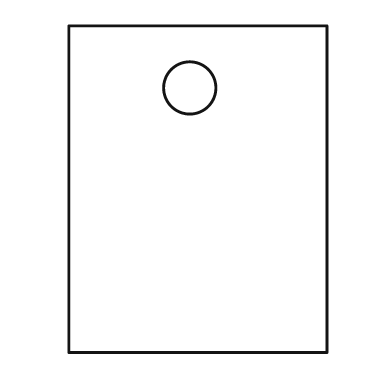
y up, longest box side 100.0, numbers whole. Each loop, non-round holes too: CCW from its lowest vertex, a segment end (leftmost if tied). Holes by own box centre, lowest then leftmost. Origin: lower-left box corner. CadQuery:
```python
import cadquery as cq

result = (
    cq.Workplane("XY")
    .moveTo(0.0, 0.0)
    .lineTo(79.0, 0.0)
    .lineTo(79.0, 100.0)
    .lineTo(0.0, 100.0)
    .close()
    .moveTo(37.0, 81.0)
    .circle(8.0)
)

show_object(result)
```